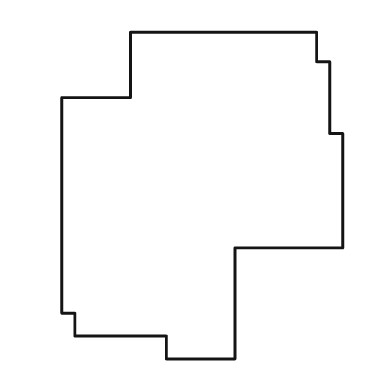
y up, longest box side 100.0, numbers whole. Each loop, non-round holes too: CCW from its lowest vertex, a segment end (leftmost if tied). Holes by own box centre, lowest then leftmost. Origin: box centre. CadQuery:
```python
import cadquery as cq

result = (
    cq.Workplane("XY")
    .moveTo(-11.0, -50.0)
    .lineTo(10.0, -50.0)
    .lineTo(10.0, -16.0)
    .lineTo(43.0, -16.0)
    .lineTo(43.0, 19.0)
    .lineTo(39.0, 19.0)
    .lineTo(39.0, 41.0)
    .lineTo(35.0, 41.0)
    .lineTo(35.0, 50.0)
    .lineTo(-22.0, 50.0)
    .lineTo(-22.0, 30.0)
    .lineTo(-43.0, 30.0)
    .lineTo(-43.0, -36.0)
    .lineTo(-39.0, -36.0)
    .lineTo(-39.0, -43.0)
    .lineTo(-11.0, -43.0)
    .close()
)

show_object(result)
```